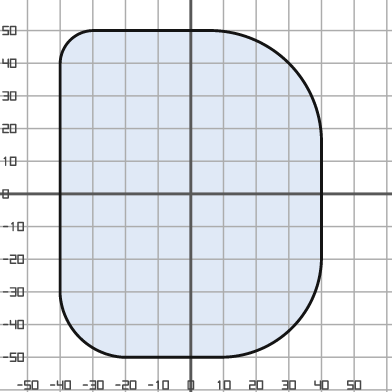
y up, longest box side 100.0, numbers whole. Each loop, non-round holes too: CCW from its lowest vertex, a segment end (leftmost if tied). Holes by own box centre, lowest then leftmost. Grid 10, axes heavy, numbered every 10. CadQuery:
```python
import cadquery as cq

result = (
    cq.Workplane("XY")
    .moveTo(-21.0, -50.0)
    .lineTo(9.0, -50.0)
    .threePointArc((31.0, -41.0), (40.0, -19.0))
    .lineTo(40.0, 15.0)
    .threePointArc((30.0, 40.0), (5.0, 50.0))
    .lineTo(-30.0, 50.0)
    .threePointArc((-37.0, 47.0), (-40.0, 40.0))
    .lineTo(-40.0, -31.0)
    .threePointArc((-34.0, -44.0), (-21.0, -50.0))
    .close()
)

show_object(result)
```